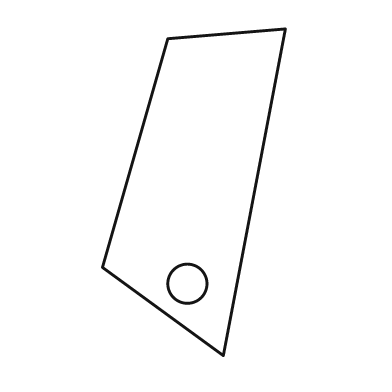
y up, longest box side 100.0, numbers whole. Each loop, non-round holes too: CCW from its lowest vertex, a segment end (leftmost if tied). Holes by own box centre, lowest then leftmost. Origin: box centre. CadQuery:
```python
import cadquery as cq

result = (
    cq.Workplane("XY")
    .moveTo(9.0, -50.0)
    .lineTo(28.0, 50.0)
    .lineTo(-8.0, 47.0)
    .lineTo(-28.0, -23.0)
    .close()
    .moveTo(-2.0, -28.0)
    .circle(6.0)
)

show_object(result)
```